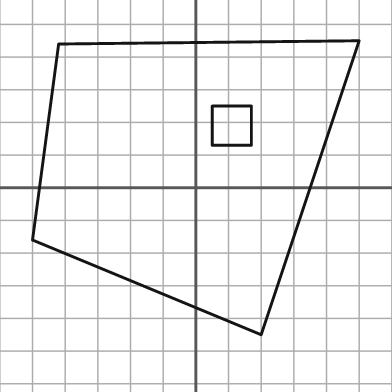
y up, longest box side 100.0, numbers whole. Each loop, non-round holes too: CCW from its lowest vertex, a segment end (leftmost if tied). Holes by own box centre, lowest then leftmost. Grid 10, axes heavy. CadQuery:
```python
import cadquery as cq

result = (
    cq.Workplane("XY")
    .moveTo(20.0, -45.0)
    .lineTo(50.0, 45.0)
    .lineTo(-42.0, 44.0)
    .lineTo(-50.0, -16.0)
    .close()
    .moveTo(5.0, 13.0)
    .lineTo(17.0, 13.0)
    .lineTo(17.0, 25.0)
    .lineTo(5.0, 25.0)
    .close()
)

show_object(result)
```